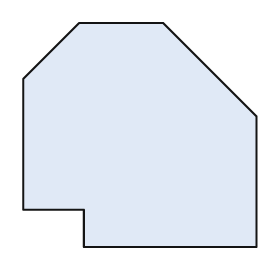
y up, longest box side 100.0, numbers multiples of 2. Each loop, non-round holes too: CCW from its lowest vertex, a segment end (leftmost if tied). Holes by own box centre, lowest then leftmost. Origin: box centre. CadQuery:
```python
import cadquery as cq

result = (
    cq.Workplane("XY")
    .moveTo(-24.0, -48.0)
    .lineTo(50.0, -48.0)
    .lineTo(50.0, 8.0)
    .lineTo(10.0, 48.0)
    .lineTo(-26.0, 48.0)
    .lineTo(-50.0, 24.0)
    .lineTo(-50.0, -32.0)
    .lineTo(-24.0, -32.0)
    .close()
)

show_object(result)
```